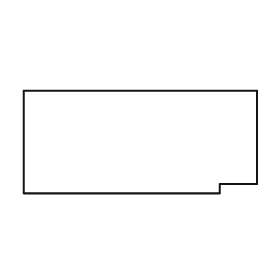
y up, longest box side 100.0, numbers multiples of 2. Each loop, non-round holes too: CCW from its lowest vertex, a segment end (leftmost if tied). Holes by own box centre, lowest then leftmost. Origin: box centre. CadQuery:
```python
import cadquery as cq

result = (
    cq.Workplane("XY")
    .moveTo(-50.0, -22.0)
    .lineTo(34.0, -22.0)
    .lineTo(34.0, -18.0)
    .lineTo(50.0, -18.0)
    .lineTo(50.0, 22.0)
    .lineTo(-50.0, 22.0)
    .close()
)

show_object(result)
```